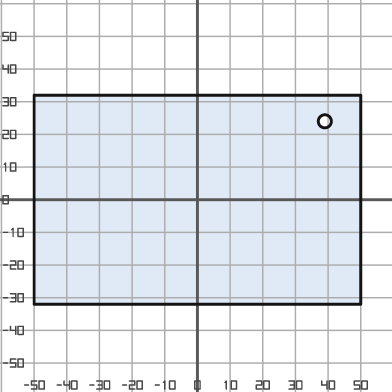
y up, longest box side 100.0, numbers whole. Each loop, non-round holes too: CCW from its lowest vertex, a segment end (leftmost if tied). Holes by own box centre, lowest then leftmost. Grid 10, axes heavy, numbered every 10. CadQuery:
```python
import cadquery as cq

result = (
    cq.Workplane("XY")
    .moveTo(-50.0, -32.0)
    .lineTo(50.0, -32.0)
    .lineTo(50.0, 32.0)
    .lineTo(-50.0, 32.0)
    .close()
    .moveTo(39.0, 24.0)
    .circle(2.0)
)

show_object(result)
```